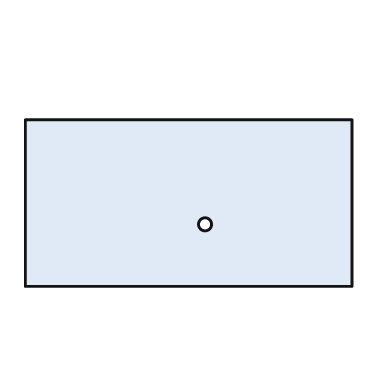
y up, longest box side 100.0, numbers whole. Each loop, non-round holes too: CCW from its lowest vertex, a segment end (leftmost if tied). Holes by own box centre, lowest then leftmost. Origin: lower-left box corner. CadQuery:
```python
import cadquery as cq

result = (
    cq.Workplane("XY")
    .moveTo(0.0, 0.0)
    .lineTo(100.0, 0.0)
    .lineTo(100.0, 51.0)
    .lineTo(0.0, 51.0)
    .close()
    .moveTo(55.0, 19.0)
    .circle(2.0)
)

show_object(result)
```